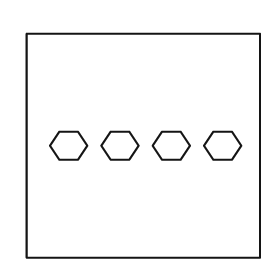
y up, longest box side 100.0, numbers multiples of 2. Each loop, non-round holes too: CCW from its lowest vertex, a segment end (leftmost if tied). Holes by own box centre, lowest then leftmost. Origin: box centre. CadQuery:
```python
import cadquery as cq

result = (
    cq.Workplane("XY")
    .moveTo(-50.0, -48.0)
    .lineTo(50.0, -48.0)
    .lineTo(50.0, 48.0)
    .lineTo(-50.0, 48.0)
    .close()
    .moveTo(-36.0, -6.0)
    .lineTo(-28.0, -6.0)
    .lineTo(-24.0, 0.0)
    .lineTo(-28.0, 6.0)
    .lineTo(-36.0, 6.0)
    .lineTo(-40.0, 0.0)
    .close()
    .moveTo(-14.0, -6.0)
    .lineTo(-6.0, -6.0)
    .lineTo(-2.0, 0.0)
    .lineTo(-6.0, 6.0)
    .lineTo(-14.0, 6.0)
    .lineTo(-18.0, 0.0)
    .close()
    .moveTo(8.0, -6.0)
    .lineTo(16.0, -6.0)
    .lineTo(20.0, 0.0)
    .lineTo(16.0, 6.0)
    .lineTo(8.0, 6.0)
    .lineTo(4.0, 0.0)
    .close()
    .moveTo(30.0, -6.0)
    .lineTo(38.0, -6.0)
    .lineTo(42.0, 0.0)
    .lineTo(38.0, 6.0)
    .lineTo(30.0, 6.0)
    .lineTo(26.0, 0.0)
    .close()
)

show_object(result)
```